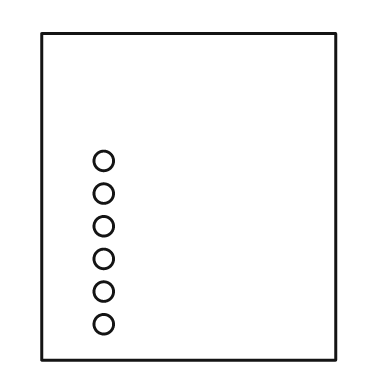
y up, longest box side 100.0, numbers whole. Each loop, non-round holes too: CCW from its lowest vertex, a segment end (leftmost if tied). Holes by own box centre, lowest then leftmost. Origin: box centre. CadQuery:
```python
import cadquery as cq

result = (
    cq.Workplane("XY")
    .moveTo(-45.0, -50.0)
    .lineTo(45.0, -50.0)
    .lineTo(45.0, 50.0)
    .lineTo(-45.0, 50.0)
    .close()
    .moveTo(-26.0, -39.0)
    .circle(3.0)
    .moveTo(-26.0, -29.0)
    .circle(3.0)
    .moveTo(-26.0, -19.0)
    .circle(3.0)
    .moveTo(-26.0, -9.0)
    .circle(3.0)
    .moveTo(-26.0, 1.0)
    .circle(3.0)
    .moveTo(-26.0, 11.0)
    .circle(3.0)
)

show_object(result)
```